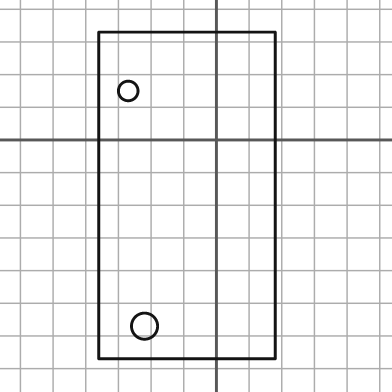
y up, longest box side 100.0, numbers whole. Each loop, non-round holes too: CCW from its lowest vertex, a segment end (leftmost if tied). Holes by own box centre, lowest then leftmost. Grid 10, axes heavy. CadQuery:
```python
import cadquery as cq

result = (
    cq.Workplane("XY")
    .moveTo(-36.0, -67.0)
    .lineTo(18.0, -67.0)
    .lineTo(18.0, 33.0)
    .lineTo(-36.0, 33.0)
    .close()
    .moveTo(-22.0, -57.0)
    .circle(4.0)
    .moveTo(-27.0, 15.0)
    .circle(3.0)
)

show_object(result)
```